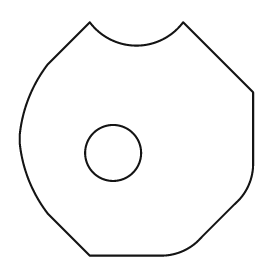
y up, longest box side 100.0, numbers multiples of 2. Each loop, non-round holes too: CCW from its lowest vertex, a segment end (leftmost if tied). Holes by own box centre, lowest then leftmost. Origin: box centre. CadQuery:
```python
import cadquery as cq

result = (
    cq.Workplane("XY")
    .moveTo(-20.0, -50.0)
    .lineTo(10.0, -50.0)
    .threePointArc((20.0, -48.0), (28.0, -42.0))
    .lineTo(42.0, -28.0)
    .threePointArc((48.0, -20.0), (50.0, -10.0))
    .lineTo(50.0, 20.0)
    .lineTo(20.0, 50.0)
    .threePointArc((0.0, 40.0), (-20.0, 50.0))
    .lineTo(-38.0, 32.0)
    .threePointArc((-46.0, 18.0), (-50.0, 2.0))
    .lineTo(-50.0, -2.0)
    .threePointArc((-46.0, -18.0), (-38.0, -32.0))
    .close()
    .moveTo(-10.0, -6.0)
    .circle(12.0)
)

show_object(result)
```